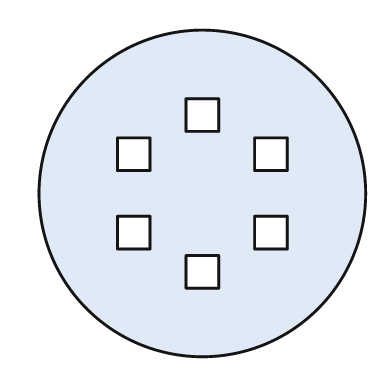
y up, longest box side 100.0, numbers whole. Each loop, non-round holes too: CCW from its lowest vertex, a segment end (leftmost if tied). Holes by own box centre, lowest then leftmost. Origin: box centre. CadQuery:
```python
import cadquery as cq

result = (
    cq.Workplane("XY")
    .moveTo(0.0, 0.0)
    .circle(50.0)
    .moveTo(-5.0, -29.0)
    .lineTo(5.0, -29.0)
    .lineTo(5.0, -19.0)
    .lineTo(-5.0, -19.0)
    .close()
    .moveTo(-26.0, -17.0)
    .lineTo(-16.0, -17.0)
    .lineTo(-16.0, -7.0)
    .lineTo(-26.0, -7.0)
    .close()
    .moveTo(16.0, -17.0)
    .lineTo(26.0, -17.0)
    .lineTo(26.0, -7.0)
    .lineTo(16.0, -7.0)
    .close()
    .moveTo(-26.0, 7.0)
    .lineTo(-16.0, 7.0)
    .lineTo(-16.0, 17.0)
    .lineTo(-26.0, 17.0)
    .close()
    .moveTo(16.0, 7.0)
    .lineTo(26.0, 7.0)
    .lineTo(26.0, 17.0)
    .lineTo(16.0, 17.0)
    .close()
    .moveTo(-5.0, 19.0)
    .lineTo(5.0, 19.0)
    .lineTo(5.0, 29.0)
    .lineTo(-5.0, 29.0)
    .close()
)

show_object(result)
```